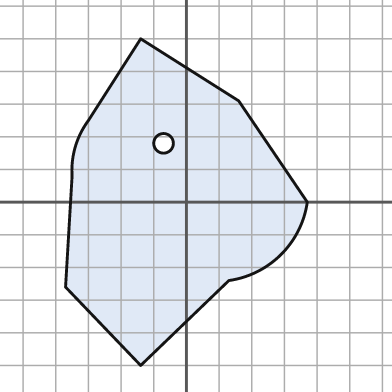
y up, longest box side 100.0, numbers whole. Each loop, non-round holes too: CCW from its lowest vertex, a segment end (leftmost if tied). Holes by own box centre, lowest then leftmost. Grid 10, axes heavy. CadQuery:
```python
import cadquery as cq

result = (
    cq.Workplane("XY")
    .moveTo(-14.0, -50.0)
    .lineTo(13.0, -24.0)
    .threePointArc((29.0, -16.0), (37.0, 0.0))
    .lineTo(16.0, 31.0)
    .lineTo(-14.0, 50.0)
    .lineTo(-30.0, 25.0)
    .threePointArc((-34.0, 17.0), (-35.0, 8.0))
    .lineTo(-37.0, -26.0)
    .close()
    .moveTo(-7.0, 18.0)
    .circle(3.0)
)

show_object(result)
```